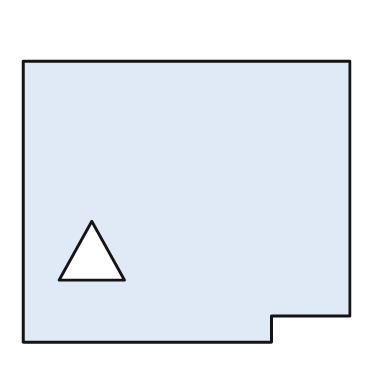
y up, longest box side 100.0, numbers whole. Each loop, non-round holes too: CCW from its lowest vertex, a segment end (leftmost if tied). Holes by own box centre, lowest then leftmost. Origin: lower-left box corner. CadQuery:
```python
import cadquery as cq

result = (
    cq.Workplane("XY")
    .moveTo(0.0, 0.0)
    .lineTo(76.0, 0.0)
    .lineTo(76.0, 8.0)
    .lineTo(100.0, 8.0)
    .lineTo(100.0, 86.0)
    .lineTo(0.0, 86.0)
    .close()
    .moveTo(11.0, 19.0)
    .lineTo(31.0, 19.0)
    .lineTo(21.0, 37.0)
    .close()
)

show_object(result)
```